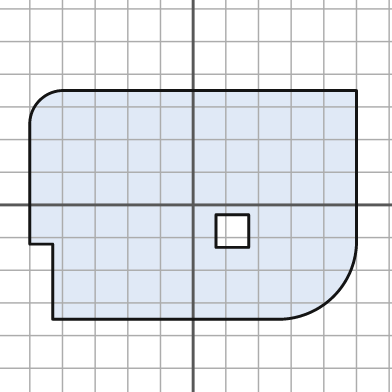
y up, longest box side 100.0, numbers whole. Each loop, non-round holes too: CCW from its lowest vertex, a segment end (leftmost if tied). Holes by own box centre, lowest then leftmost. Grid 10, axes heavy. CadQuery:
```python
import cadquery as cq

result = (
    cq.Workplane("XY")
    .moveTo(-43.0, -35.0)
    .lineTo(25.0, -35.0)
    .threePointArc((43.0, -28.0), (50.0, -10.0))
    .lineTo(50.0, 35.0)
    .lineTo(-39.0, 35.0)
    .threePointArc((-47.0, 32.0), (-50.0, 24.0))
    .lineTo(-50.0, -12.0)
    .lineTo(-43.0, -12.0)
    .close()
    .moveTo(7.0, -13.0)
    .lineTo(17.0, -13.0)
    .lineTo(17.0, -3.0)
    .lineTo(7.0, -3.0)
    .close()
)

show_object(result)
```